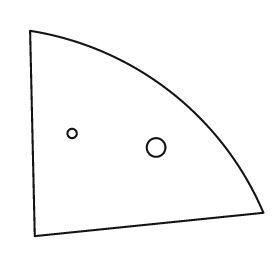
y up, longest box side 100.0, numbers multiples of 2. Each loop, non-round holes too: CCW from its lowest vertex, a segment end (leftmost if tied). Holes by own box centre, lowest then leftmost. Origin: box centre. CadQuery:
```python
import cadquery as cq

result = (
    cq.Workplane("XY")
    .moveTo(-48.0, -44.0)
    .lineTo(50.0, -34.0)
    .threePointArc((10.0, 18.0), (-50.0, 44.0))
    .close()
    .moveTo(4.0, -6.0)
    .circle(4.0)
    .moveTo(-32.0, 0.0)
    .circle(2.0)
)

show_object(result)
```